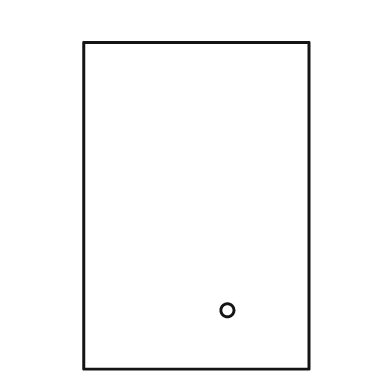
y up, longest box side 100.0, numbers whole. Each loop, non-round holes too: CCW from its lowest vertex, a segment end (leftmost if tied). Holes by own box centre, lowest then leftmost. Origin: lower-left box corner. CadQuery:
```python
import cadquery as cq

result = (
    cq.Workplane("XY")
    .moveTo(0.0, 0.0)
    .lineTo(69.0, 0.0)
    .lineTo(69.0, 100.0)
    .lineTo(0.0, 100.0)
    .close()
    .moveTo(44.0, 18.0)
    .circle(2.0)
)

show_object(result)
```